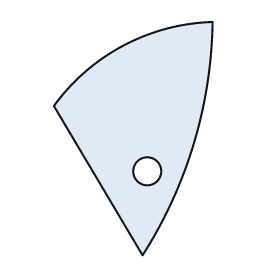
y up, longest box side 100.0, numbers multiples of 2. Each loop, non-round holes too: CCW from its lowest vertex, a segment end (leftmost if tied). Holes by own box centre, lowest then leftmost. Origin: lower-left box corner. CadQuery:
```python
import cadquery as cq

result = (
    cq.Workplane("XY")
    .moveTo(38.0, 0.0)
    .threePointArc((60.0, 48.0), (68.0, 100.0))
    .threePointArc((30.0, 90.0), (0.0, 64.0))
    .close()
    .moveTo(40.0, 36.0)
    .circle(6.0)
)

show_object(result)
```